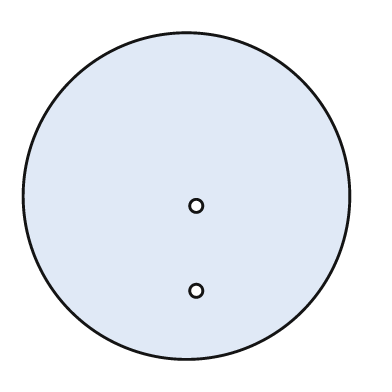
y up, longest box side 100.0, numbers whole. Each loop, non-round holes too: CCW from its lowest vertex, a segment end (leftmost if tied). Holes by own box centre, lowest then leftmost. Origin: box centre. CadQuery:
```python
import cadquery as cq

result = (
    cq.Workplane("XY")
    .moveTo(0.0, 0.0)
    .circle(50.0)
    .moveTo(3.0, -29.0)
    .circle(2.0)
    .moveTo(3.0, -3.0)
    .circle(2.0)
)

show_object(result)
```